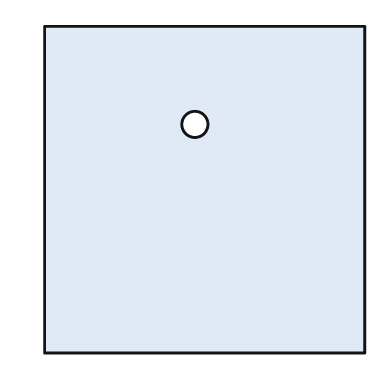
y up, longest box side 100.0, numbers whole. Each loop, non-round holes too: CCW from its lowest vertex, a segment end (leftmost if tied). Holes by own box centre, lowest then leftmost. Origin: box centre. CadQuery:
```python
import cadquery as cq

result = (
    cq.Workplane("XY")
    .moveTo(-49.0, -50.0)
    .lineTo(49.0, -50.0)
    .lineTo(49.0, 50.0)
    .lineTo(-49.0, 50.0)
    .close()
    .moveTo(-3.0, 20.0)
    .circle(4.0)
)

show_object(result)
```